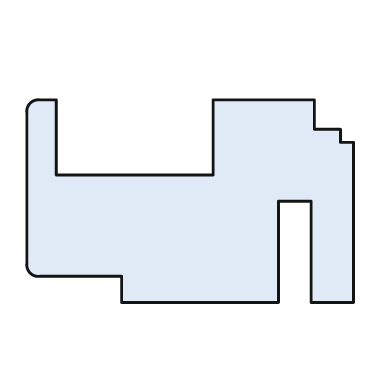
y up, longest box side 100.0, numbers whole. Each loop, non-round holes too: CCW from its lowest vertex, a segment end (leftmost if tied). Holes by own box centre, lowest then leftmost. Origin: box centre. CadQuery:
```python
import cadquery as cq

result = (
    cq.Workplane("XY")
    .moveTo(-21.0, -31.0)
    .lineTo(27.0, -31.0)
    .lineTo(27.0, 0.0)
    .lineTo(37.0, 0.0)
    .lineTo(37.0, -31.0)
    .lineTo(50.0, -31.0)
    .lineTo(50.0, 18.0)
    .lineTo(46.0, 18.0)
    .lineTo(46.0, 22.0)
    .lineTo(38.0, 22.0)
    .lineTo(38.0, 31.0)
    .lineTo(7.0, 31.0)
    .lineTo(7.0, 8.0)
    .lineTo(-41.0, 8.0)
    .lineTo(-41.0, 31.0)
    .lineTo(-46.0, 31.0)
    .threePointArc((-49.0, 30.0), (-50.0, 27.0))
    .lineTo(-50.0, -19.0)
    .threePointArc((-49.0, -22.0), (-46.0, -23.0))
    .lineTo(-21.0, -23.0)
    .close()
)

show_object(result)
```